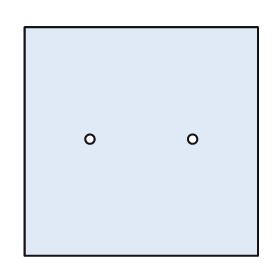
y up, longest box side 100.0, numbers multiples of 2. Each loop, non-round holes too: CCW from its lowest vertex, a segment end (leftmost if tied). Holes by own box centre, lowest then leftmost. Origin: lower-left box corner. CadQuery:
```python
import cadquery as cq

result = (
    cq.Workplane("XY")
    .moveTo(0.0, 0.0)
    .lineTo(100.0, 0.0)
    .lineTo(100.0, 98.0)
    .lineTo(0.0, 98.0)
    .close()
    .moveTo(28.0, 50.0)
    .circle(2.0)
    .moveTo(72.0, 50.0)
    .circle(2.0)
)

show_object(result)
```